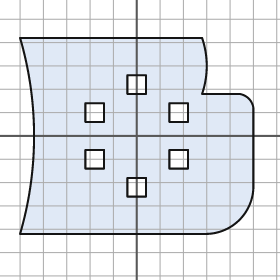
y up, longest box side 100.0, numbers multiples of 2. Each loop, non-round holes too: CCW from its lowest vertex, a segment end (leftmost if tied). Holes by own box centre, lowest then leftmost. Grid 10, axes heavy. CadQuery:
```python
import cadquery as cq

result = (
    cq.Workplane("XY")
    .moveTo(-50.0, -42.0)
    .lineTo(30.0, -42.0)
    .threePointArc((44.0, -36.0), (50.0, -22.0))
    .lineTo(50.0, 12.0)
    .threePointArc((48.0, 16.0), (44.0, 18.0))
    .lineTo(28.0, 18.0)
    .threePointArc((30.0, 30.0), (28.0, 42.0))
    .lineTo(-50.0, 42.0)
    .threePointArc((-44.0, 0.0), (-50.0, -42.0))
    .close()
    .moveTo(-4.0, -26.0)
    .lineTo(4.0, -26.0)
    .lineTo(4.0, -18.0)
    .lineTo(-4.0, -18.0)
    .close()
    .moveTo(-22.0, -14.0)
    .lineTo(-14.0, -14.0)
    .lineTo(-14.0, -6.0)
    .lineTo(-22.0, -6.0)
    .close()
    .moveTo(14.0, -14.0)
    .lineTo(22.0, -14.0)
    .lineTo(22.0, -6.0)
    .lineTo(14.0, -6.0)
    .close()
    .moveTo(-22.0, 6.0)
    .lineTo(-14.0, 6.0)
    .lineTo(-14.0, 14.0)
    .lineTo(-22.0, 14.0)
    .close()
    .moveTo(14.0, 6.0)
    .lineTo(22.0, 6.0)
    .lineTo(22.0, 14.0)
    .lineTo(14.0, 14.0)
    .close()
    .moveTo(-4.0, 18.0)
    .lineTo(4.0, 18.0)
    .lineTo(4.0, 26.0)
    .lineTo(-4.0, 26.0)
    .close()
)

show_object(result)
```